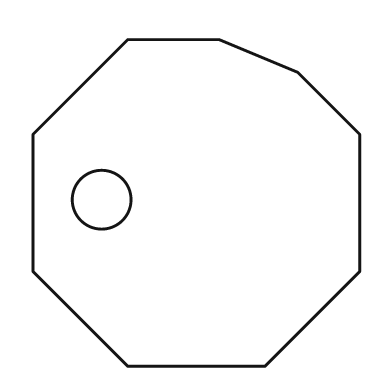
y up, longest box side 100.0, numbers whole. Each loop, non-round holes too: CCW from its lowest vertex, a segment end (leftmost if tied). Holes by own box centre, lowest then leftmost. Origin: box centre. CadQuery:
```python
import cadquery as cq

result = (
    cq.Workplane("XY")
    .moveTo(-21.0, -50.0)
    .lineTo(21.0, -50.0)
    .lineTo(50.0, -21.0)
    .lineTo(50.0, 21.0)
    .lineTo(31.0, 40.0)
    .lineTo(7.0, 50.0)
    .lineTo(-21.0, 50.0)
    .lineTo(-50.0, 21.0)
    .lineTo(-50.0, -21.0)
    .close()
    .moveTo(-29.0, 1.0)
    .circle(9.0)
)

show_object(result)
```